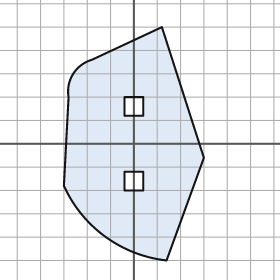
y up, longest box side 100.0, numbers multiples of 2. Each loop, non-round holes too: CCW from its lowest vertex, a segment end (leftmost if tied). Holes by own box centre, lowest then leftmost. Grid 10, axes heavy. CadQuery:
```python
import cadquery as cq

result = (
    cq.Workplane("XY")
    .moveTo(14.0, -50.0)
    .lineTo(30.0, -6.0)
    .lineTo(12.0, 50.0)
    .lineTo(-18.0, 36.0)
    .threePointArc((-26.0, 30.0), (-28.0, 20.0))
    .lineTo(-30.0, -18.0)
    .threePointArc((-12.0, -40.0), (14.0, -50.0))
    .close()
    .moveTo(-4.0, -20.0)
    .lineTo(4.0, -20.0)
    .lineTo(4.0, -12.0)
    .lineTo(-4.0, -12.0)
    .close()
    .moveTo(-4.0, 12.0)
    .lineTo(4.0, 12.0)
    .lineTo(4.0, 20.0)
    .lineTo(-4.0, 20.0)
    .close()
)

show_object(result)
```